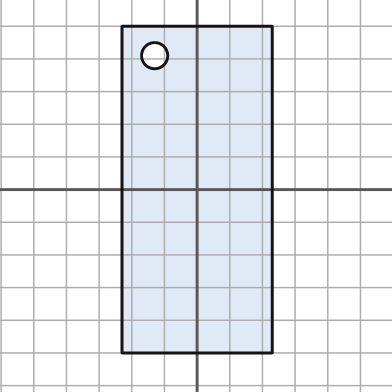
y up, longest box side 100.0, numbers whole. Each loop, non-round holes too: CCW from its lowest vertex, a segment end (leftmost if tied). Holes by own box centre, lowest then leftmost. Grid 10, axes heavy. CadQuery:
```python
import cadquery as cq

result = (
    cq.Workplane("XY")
    .moveTo(-23.0, -50.0)
    .lineTo(23.0, -50.0)
    .lineTo(23.0, 50.0)
    .lineTo(-23.0, 50.0)
    .close()
    .moveTo(-13.0, 41.0)
    .circle(4.0)
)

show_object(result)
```